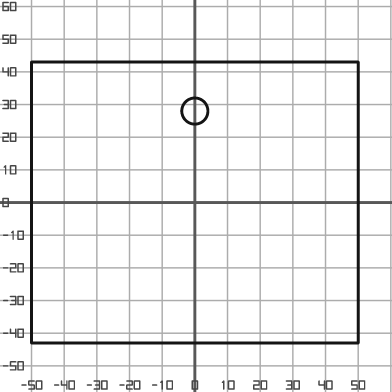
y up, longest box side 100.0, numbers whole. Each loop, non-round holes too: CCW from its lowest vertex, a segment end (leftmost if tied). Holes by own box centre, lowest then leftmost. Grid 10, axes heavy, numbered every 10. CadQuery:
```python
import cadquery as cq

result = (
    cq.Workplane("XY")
    .moveTo(-50.0, -43.0)
    .lineTo(50.0, -43.0)
    .lineTo(50.0, 43.0)
    .lineTo(-50.0, 43.0)
    .close()
    .moveTo(0.0, 28.0)
    .circle(4.0)
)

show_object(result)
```